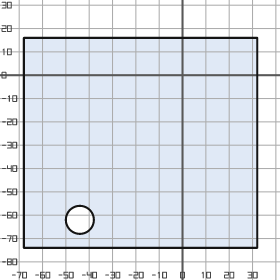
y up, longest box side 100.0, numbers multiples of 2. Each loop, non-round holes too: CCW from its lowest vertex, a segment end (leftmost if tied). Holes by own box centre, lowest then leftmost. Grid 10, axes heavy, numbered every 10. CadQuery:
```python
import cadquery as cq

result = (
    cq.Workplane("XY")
    .moveTo(-68.0, -74.0)
    .lineTo(32.0, -74.0)
    .lineTo(32.0, 16.0)
    .lineTo(-68.0, 16.0)
    .close()
    .moveTo(-44.0, -62.0)
    .circle(6.0)
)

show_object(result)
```